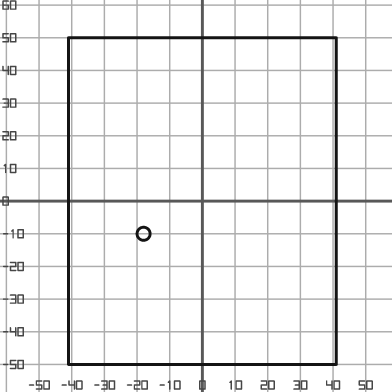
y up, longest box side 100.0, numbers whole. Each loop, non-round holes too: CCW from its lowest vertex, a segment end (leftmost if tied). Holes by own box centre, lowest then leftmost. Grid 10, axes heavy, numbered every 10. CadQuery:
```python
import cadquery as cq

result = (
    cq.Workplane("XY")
    .moveTo(-41.0, -50.0)
    .lineTo(41.0, -50.0)
    .lineTo(41.0, 50.0)
    .lineTo(-41.0, 50.0)
    .close()
    .moveTo(-18.0, -10.0)
    .circle(2.0)
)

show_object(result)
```